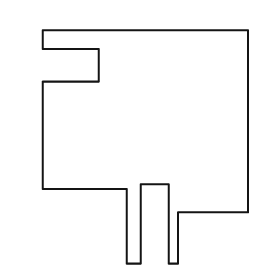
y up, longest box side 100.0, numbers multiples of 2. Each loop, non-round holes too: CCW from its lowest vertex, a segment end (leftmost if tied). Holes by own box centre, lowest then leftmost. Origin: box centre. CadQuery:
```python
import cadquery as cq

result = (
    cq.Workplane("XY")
    .moveTo(-8.0, -50.0)
    .lineTo(-2.0, -50.0)
    .lineTo(-2.0, -16.0)
    .lineTo(10.0, -16.0)
    .lineTo(10.0, -50.0)
    .lineTo(14.0, -50.0)
    .lineTo(14.0, -28.0)
    .lineTo(44.0, -28.0)
    .lineTo(44.0, 50.0)
    .lineTo(-44.0, 50.0)
    .lineTo(-44.0, 42.0)
    .lineTo(-20.0, 42.0)
    .lineTo(-20.0, 28.0)
    .lineTo(-44.0, 28.0)
    .lineTo(-44.0, -18.0)
    .lineTo(-8.0, -18.0)
    .close()
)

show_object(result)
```